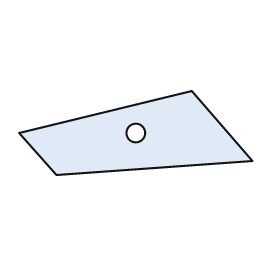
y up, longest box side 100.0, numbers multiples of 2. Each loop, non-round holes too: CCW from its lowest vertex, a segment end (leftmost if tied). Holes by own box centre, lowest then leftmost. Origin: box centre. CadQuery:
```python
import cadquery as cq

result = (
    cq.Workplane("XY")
    .moveTo(-34.0, -18.0)
    .lineTo(50.0, -12.0)
    .lineTo(24.0, 18.0)
    .lineTo(-50.0, 0.0)
    .close()
    .moveTo(0.0, 0.0)
    .circle(4.0)
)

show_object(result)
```